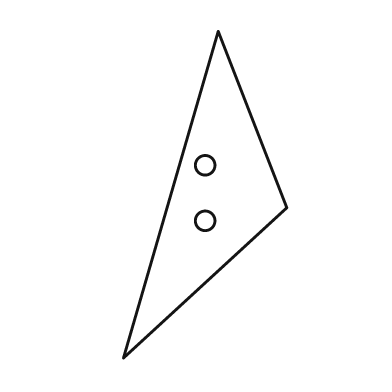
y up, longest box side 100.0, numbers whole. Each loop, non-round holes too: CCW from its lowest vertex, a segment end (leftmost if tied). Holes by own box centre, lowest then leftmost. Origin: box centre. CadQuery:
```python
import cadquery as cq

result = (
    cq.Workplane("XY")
    .moveTo(-25.0, -50.0)
    .lineTo(25.0, -4.0)
    .lineTo(4.0, 50.0)
    .close()
    .moveTo(0.0, -8.0)
    .circle(3.0)
    .moveTo(0.0, 9.0)
    .circle(3.0)
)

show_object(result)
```